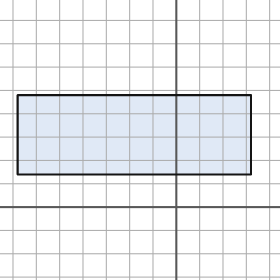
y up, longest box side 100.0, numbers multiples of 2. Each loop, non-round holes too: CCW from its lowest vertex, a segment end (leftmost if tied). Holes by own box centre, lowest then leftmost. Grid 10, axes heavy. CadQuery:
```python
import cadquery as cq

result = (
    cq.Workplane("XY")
    .moveTo(-68.0, 14.0)
    .lineTo(32.0, 14.0)
    .lineTo(32.0, 48.0)
    .lineTo(-68.0, 48.0)
    .close()
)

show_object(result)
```